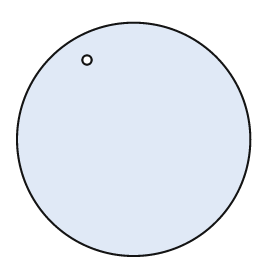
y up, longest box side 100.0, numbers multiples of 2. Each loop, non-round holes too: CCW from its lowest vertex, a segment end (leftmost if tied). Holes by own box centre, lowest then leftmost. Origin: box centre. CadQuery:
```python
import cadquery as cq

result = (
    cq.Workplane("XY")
    .moveTo(0.0, 0.0)
    .circle(50.0)
    .moveTo(-20.0, 34.0)
    .circle(2.0)
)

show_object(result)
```